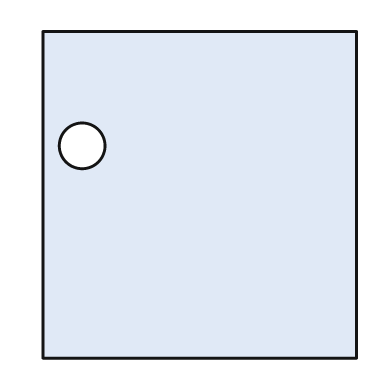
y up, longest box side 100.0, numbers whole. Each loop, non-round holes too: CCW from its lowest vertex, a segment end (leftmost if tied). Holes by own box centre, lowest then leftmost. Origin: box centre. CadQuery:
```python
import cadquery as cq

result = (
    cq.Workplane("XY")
    .moveTo(-48.0, -50.0)
    .lineTo(48.0, -50.0)
    .lineTo(48.0, 50.0)
    .lineTo(-48.0, 50.0)
    .close()
    .moveTo(-36.0, 15.0)
    .circle(7.0)
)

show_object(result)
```